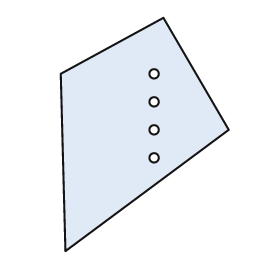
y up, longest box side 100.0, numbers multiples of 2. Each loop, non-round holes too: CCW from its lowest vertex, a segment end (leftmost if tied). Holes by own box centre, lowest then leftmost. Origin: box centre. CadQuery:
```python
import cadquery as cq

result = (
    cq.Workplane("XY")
    .moveTo(-34.0, -50.0)
    .lineTo(36.0, 2.0)
    .lineTo(8.0, 50.0)
    .lineTo(-36.0, 26.0)
    .close()
    .moveTo(4.0, -10.0)
    .circle(2.0)
    .moveTo(4.0, 2.0)
    .circle(2.0)
    .moveTo(4.0, 14.0)
    .circle(2.0)
    .moveTo(4.0, 26.0)
    .circle(2.0)
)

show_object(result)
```